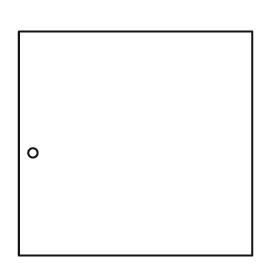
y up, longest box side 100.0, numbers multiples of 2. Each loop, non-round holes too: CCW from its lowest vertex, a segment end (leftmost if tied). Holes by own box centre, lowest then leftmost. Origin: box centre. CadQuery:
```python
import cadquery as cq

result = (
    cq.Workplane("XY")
    .moveTo(-50.0, -48.0)
    .lineTo(50.0, -48.0)
    .lineTo(50.0, 48.0)
    .lineTo(-50.0, 48.0)
    .close()
    .moveTo(-44.0, -4.0)
    .circle(2.0)
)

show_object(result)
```